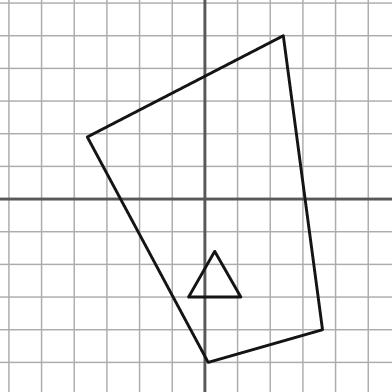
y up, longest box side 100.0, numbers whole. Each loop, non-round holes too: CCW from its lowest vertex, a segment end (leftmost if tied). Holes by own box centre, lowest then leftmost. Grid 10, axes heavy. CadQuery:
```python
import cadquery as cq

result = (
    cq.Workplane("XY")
    .moveTo(1.0, -50.0)
    .lineTo(36.0, -40.0)
    .lineTo(24.0, 50.0)
    .lineTo(-36.0, 19.0)
    .close()
    .moveTo(-5.0, -30.0)
    .lineTo(11.0, -30.0)
    .lineTo(3.0, -16.0)
    .close()
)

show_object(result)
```